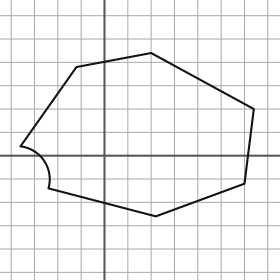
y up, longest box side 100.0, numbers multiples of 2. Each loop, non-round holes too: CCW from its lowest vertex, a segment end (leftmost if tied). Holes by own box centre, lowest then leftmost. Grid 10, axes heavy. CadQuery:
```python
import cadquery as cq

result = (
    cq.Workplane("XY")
    .moveTo(22.0, -26.0)
    .lineTo(60.0, -12.0)
    .lineTo(64.0, 20.0)
    .lineTo(20.0, 44.0)
    .lineTo(-12.0, 38.0)
    .lineTo(-36.0, 4.0)
    .threePointArc((-26.0, -2.0), (-24.0, -14.0))
    .close()
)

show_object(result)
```